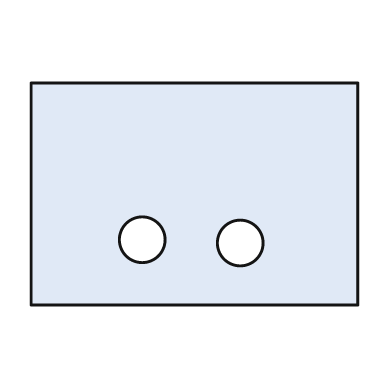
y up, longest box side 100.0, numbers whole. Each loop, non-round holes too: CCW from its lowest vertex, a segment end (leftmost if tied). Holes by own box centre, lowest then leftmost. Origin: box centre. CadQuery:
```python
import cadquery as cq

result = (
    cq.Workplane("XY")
    .moveTo(-50.0, -34.0)
    .lineTo(50.0, -34.0)
    .lineTo(50.0, 34.0)
    .lineTo(-50.0, 34.0)
    .close()
    .moveTo(14.0, -15.0)
    .circle(7.0)
    .moveTo(-16.0, -14.0)
    .circle(7.0)
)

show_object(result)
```